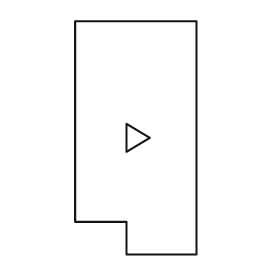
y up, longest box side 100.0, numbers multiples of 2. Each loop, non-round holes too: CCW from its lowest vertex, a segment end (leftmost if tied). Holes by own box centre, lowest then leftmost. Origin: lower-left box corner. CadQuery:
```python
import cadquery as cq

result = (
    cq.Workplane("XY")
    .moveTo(22.0, 0.0)
    .lineTo(52.0, 0.0)
    .lineTo(52.0, 100.0)
    .lineTo(0.0, 100.0)
    .lineTo(0.0, 14.0)
    .lineTo(22.0, 14.0)
    .close()
    .moveTo(22.0, 44.0)
    .lineTo(32.0, 50.0)
    .lineTo(22.0, 56.0)
    .close()
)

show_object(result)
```